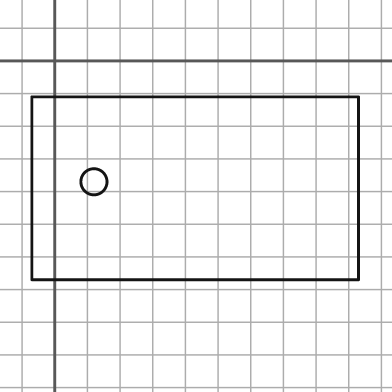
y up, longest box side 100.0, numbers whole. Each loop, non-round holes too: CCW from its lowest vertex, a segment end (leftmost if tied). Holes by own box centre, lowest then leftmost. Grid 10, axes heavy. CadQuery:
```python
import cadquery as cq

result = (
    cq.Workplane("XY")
    .moveTo(-7.0, -67.0)
    .lineTo(93.0, -67.0)
    .lineTo(93.0, -11.0)
    .lineTo(-7.0, -11.0)
    .close()
    .moveTo(12.0, -37.0)
    .circle(4.0)
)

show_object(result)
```